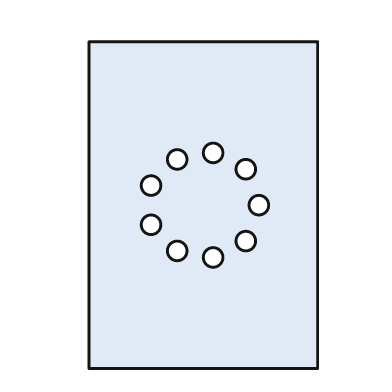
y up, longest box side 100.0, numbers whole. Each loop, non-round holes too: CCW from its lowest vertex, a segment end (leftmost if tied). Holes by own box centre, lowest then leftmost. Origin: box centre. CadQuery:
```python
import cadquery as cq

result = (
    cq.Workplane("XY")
    .moveTo(-35.0, -50.0)
    .lineTo(35.0, -50.0)
    .lineTo(35.0, 50.0)
    .lineTo(-35.0, 50.0)
    .close()
    .moveTo(3.0, -16.0)
    .circle(3.0)
    .moveTo(-8.0, -14.0)
    .circle(3.0)
    .moveTo(13.0, -11.0)
    .circle(3.0)
    .moveTo(-16.0, -6.0)
    .circle(3.0)
    .moveTo(17.0, 0.0)
    .circle(3.0)
    .moveTo(-16.0, 6.0)
    .circle(3.0)
    .moveTo(13.0, 11.0)
    .circle(3.0)
    .moveTo(-8.0, 14.0)
    .circle(3.0)
    .moveTo(3.0, 16.0)
    .circle(3.0)
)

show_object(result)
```